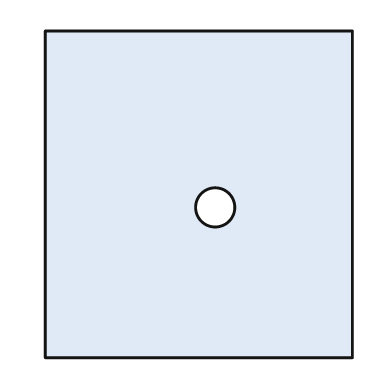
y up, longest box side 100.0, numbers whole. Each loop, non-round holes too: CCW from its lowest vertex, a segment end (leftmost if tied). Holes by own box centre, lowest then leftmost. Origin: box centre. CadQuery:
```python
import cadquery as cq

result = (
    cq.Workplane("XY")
    .moveTo(-47.0, -50.0)
    .lineTo(47.0, -50.0)
    .lineTo(47.0, 50.0)
    .lineTo(-47.0, 50.0)
    .close()
    .moveTo(5.0, -4.0)
    .circle(6.0)
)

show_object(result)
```